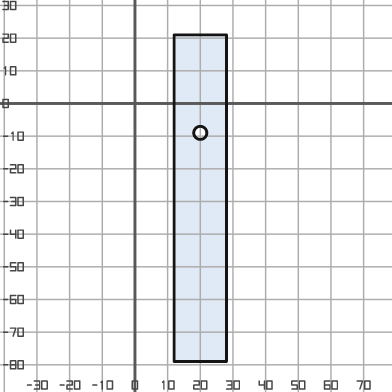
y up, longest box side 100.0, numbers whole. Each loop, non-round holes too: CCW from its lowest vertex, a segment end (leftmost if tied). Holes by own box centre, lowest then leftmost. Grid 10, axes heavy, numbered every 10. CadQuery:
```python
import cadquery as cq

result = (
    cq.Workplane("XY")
    .moveTo(12.0, -79.0)
    .lineTo(28.0, -79.0)
    .lineTo(28.0, 21.0)
    .lineTo(12.0, 21.0)
    .close()
    .moveTo(20.0, -9.0)
    .circle(2.0)
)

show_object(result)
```